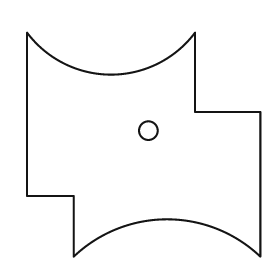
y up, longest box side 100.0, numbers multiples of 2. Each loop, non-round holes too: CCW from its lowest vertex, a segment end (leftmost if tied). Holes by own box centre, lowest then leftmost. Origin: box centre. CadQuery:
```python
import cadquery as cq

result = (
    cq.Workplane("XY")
    .moveTo(-30.0, -48.0)
    .threePointArc((10.0, -32.0), (50.0, -48.0))
    .lineTo(50.0, 14.0)
    .lineTo(22.0, 14.0)
    .lineTo(22.0, 48.0)
    .threePointArc((-14.0, 30.0), (-50.0, 48.0))
    .lineTo(-50.0, -22.0)
    .lineTo(-30.0, -22.0)
    .close()
    .moveTo(2.0, 6.0)
    .circle(4.0)
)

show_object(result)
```